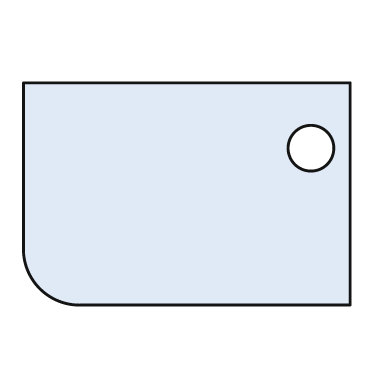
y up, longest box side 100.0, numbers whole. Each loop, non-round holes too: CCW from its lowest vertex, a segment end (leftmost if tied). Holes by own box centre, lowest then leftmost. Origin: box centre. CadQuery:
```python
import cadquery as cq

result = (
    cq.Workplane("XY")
    .moveTo(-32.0, -34.0)
    .lineTo(50.0, -34.0)
    .lineTo(50.0, 34.0)
    .lineTo(-50.0, 34.0)
    .lineTo(-50.0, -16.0)
    .threePointArc((-45.0, -29.0), (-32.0, -34.0))
    .close()
    .moveTo(38.0, 14.0)
    .circle(7.0)
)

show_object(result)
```